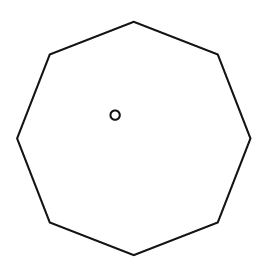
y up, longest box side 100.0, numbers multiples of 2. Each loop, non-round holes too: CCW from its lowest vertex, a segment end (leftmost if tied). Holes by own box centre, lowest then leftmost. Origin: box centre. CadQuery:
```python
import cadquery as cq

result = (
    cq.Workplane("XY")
    .moveTo(0.0, -50.0)
    .lineTo(36.0, -36.0)
    .lineTo(50.0, 0.0)
    .lineTo(36.0, 36.0)
    .lineTo(0.0, 50.0)
    .lineTo(-36.0, 36.0)
    .lineTo(-50.0, 0.0)
    .lineTo(-36.0, -36.0)
    .close()
    .moveTo(-8.0, 10.0)
    .circle(2.0)
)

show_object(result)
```